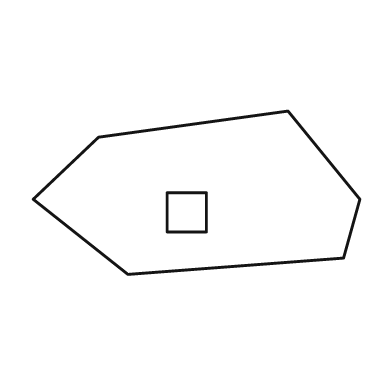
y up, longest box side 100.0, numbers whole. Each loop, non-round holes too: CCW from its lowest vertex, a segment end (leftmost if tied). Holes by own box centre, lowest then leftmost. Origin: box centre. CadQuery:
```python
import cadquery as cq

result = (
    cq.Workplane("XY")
    .moveTo(-21.0, -25.0)
    .lineTo(45.0, -20.0)
    .lineTo(50.0, -2.0)
    .lineTo(28.0, 25.0)
    .lineTo(-30.0, 17.0)
    .lineTo(-50.0, -2.0)
    .close()
    .moveTo(-9.0, -12.0)
    .lineTo(3.0, -12.0)
    .lineTo(3.0, 0.0)
    .lineTo(-9.0, 0.0)
    .close()
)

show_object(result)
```